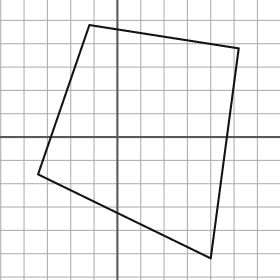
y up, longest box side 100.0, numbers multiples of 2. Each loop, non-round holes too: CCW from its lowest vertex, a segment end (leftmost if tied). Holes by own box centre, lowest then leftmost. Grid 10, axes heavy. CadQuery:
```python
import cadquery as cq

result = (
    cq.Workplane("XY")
    .moveTo(40.0, -52.0)
    .lineTo(52.0, 38.0)
    .lineTo(-12.0, 48.0)
    .lineTo(-34.0, -16.0)
    .close()
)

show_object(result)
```